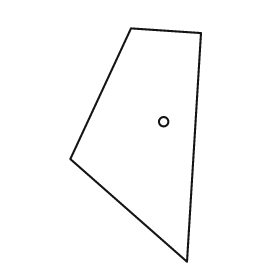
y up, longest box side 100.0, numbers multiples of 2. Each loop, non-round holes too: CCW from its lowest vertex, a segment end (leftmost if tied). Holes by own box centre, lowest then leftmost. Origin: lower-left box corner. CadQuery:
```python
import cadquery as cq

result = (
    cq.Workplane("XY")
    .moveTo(50.0, 0.0)
    .lineTo(56.0, 98.0)
    .lineTo(26.0, 100.0)
    .lineTo(0.0, 44.0)
    .close()
    .moveTo(40.0, 60.0)
    .circle(2.0)
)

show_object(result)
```